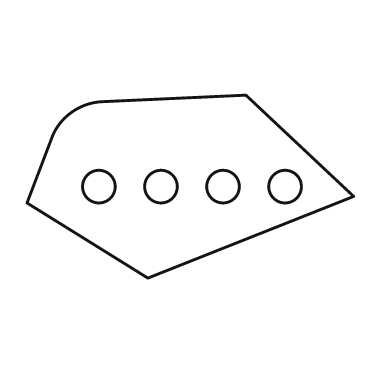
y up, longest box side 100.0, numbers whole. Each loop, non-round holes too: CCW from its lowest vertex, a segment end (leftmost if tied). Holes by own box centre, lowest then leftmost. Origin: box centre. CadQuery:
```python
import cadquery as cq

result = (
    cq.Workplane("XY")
    .moveTo(-13.0, -28.0)
    .lineTo(50.0, -3.0)
    .lineTo(17.0, 28.0)
    .lineTo(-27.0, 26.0)
    .threePointArc((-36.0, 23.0), (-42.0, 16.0))
    .lineTo(-50.0, -5.0)
    .close()
    .moveTo(-28.0, 0.0)
    .circle(5.0)
    .moveTo(-9.0, 0.0)
    .circle(5.0)
    .moveTo(10.0, 0.0)
    .circle(5.0)
    .moveTo(29.0, 0.0)
    .circle(5.0)
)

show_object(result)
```